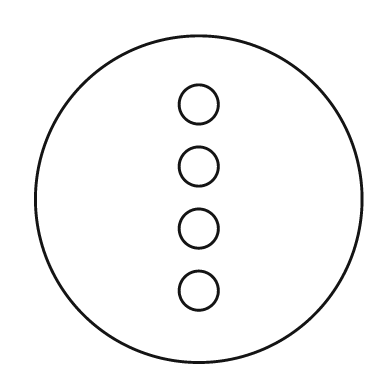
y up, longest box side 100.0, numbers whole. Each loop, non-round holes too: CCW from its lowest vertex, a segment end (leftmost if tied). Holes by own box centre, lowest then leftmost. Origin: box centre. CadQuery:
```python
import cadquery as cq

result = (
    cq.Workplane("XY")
    .moveTo(0.0, 0.0)
    .circle(50.0)
    .moveTo(0.0, -28.0)
    .circle(6.0)
    .moveTo(0.0, -9.0)
    .circle(6.0)
    .moveTo(0.0, 10.0)
    .circle(6.0)
    .moveTo(0.0, 29.0)
    .circle(6.0)
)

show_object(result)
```